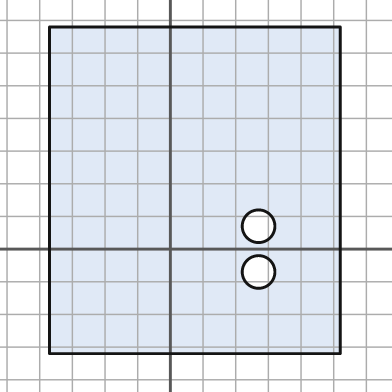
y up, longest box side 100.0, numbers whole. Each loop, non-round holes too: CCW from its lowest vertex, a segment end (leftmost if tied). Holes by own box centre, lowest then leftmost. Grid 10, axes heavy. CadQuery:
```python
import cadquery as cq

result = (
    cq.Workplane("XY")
    .moveTo(-37.0, -32.0)
    .lineTo(52.0, -32.0)
    .lineTo(52.0, 68.0)
    .lineTo(-37.0, 68.0)
    .close()
    .moveTo(27.0, -7.0)
    .circle(5.0)
    .moveTo(27.0, 7.0)
    .circle(5.0)
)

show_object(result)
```